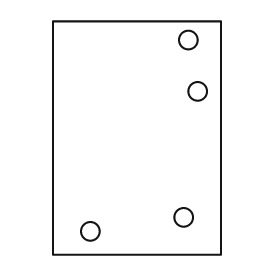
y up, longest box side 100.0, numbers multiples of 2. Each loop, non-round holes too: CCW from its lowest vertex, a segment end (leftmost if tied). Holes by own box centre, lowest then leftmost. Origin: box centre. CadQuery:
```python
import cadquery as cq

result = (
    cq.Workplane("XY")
    .moveTo(-36.0, -50.0)
    .lineTo(36.0, -50.0)
    .lineTo(36.0, 50.0)
    .lineTo(-36.0, 50.0)
    .close()
    .moveTo(-20.0, -40.0)
    .circle(4.0)
    .moveTo(20.0, -34.0)
    .circle(4.0)
    .moveTo(26.0, 20.0)
    .circle(4.0)
    .moveTo(22.0, 42.0)
    .circle(4.0)
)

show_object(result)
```